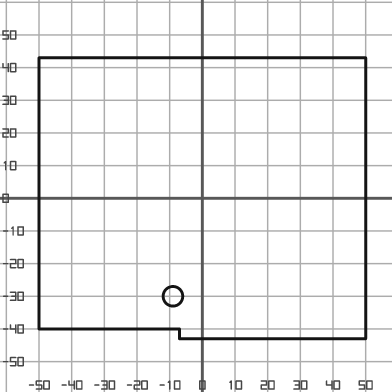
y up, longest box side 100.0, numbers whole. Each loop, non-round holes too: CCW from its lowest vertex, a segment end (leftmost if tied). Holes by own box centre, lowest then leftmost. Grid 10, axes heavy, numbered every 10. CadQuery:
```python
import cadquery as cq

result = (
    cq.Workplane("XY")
    .moveTo(-7.0, -43.0)
    .lineTo(50.0, -43.0)
    .lineTo(50.0, 43.0)
    .lineTo(-50.0, 43.0)
    .lineTo(-50.0, -40.0)
    .lineTo(-7.0, -40.0)
    .close()
    .moveTo(-9.0, -30.0)
    .circle(3.0)
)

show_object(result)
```